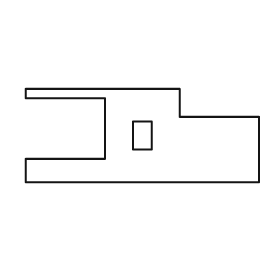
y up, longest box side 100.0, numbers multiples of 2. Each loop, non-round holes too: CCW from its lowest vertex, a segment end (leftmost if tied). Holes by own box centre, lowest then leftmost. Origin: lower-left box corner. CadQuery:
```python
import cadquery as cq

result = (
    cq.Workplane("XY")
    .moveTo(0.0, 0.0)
    .lineTo(100.0, 0.0)
    .lineTo(100.0, 28.0)
    .lineTo(66.0, 28.0)
    .lineTo(66.0, 40.0)
    .lineTo(0.0, 40.0)
    .lineTo(0.0, 36.0)
    .lineTo(34.0, 36.0)
    .lineTo(34.0, 10.0)
    .lineTo(0.0, 10.0)
    .close()
    .moveTo(46.0, 14.0)
    .lineTo(54.0, 14.0)
    .lineTo(54.0, 26.0)
    .lineTo(46.0, 26.0)
    .close()
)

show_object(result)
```